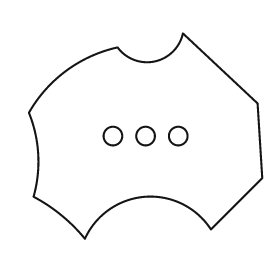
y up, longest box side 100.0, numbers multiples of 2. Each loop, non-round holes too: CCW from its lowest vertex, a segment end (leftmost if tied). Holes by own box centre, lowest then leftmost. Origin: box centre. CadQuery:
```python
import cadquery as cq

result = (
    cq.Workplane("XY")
    .moveTo(-26.0, -44.0)
    .threePointArc((0.0, -26.0), (28.0, -40.0))
    .lineTo(50.0, -18.0)
    .lineTo(48.0, 14.0)
    .lineTo(16.0, 44.0)
    .threePointArc((4.0, 32.0), (-12.0, 38.0))
    .threePointArc((-34.0, 28.0), (-50.0, 10.0))
    .threePointArc((-46.0, -8.0), (-48.0, -26.0))
    .threePointArc((-36.0, -34.0), (-26.0, -44.0))
    .close()
    .moveTo(-14.0, 0.0)
    .circle(4.0)
    .moveTo(0.0, 0.0)
    .circle(4.0)
    .moveTo(14.0, 0.0)
    .circle(4.0)
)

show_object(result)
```